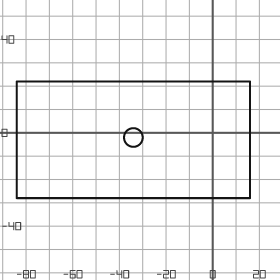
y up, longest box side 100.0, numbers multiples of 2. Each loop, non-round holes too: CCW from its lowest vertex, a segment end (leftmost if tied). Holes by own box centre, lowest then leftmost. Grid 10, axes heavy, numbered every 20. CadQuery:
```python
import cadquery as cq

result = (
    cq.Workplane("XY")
    .moveTo(-84.0, -28.0)
    .lineTo(16.0, -28.0)
    .lineTo(16.0, 22.0)
    .lineTo(-84.0, 22.0)
    .close()
    .moveTo(-34.0, -2.0)
    .circle(4.0)
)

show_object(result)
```